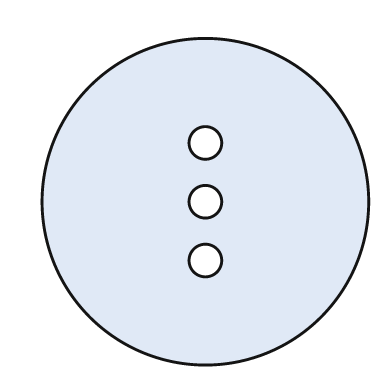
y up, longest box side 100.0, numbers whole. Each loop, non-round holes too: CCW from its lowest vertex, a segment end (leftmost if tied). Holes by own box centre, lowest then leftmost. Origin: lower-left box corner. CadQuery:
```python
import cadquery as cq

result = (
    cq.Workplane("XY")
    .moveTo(50.0, 50.0)
    .circle(50.0)
    .moveTo(50.0, 32.0)
    .circle(5.0)
    .moveTo(50.0, 50.0)
    .circle(5.0)
    .moveTo(50.0, 68.0)
    .circle(5.0)
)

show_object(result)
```